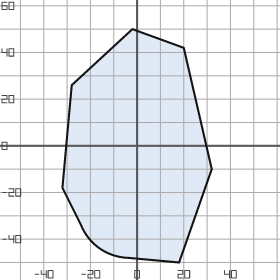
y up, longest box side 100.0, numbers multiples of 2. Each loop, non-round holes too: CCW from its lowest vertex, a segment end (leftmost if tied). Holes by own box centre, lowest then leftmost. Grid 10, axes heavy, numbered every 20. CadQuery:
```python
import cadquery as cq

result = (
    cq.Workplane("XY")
    .moveTo(18.0, -50.0)
    .lineTo(32.0, -10.0)
    .lineTo(20.0, 42.0)
    .lineTo(-2.0, 50.0)
    .lineTo(-28.0, 26.0)
    .lineTo(-32.0, -18.0)
    .lineTo(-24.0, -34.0)
    .threePointArc((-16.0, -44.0), (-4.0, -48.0))
    .close()
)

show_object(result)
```